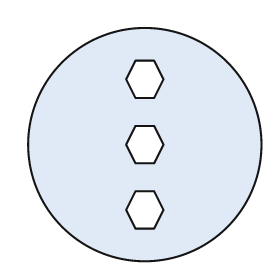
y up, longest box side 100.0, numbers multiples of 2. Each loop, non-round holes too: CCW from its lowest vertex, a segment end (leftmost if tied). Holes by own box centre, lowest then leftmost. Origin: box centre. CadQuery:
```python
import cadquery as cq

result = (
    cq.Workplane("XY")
    .moveTo(0.0, 0.0)
    .circle(50.0)
    .moveTo(-4.0, -36.0)
    .lineTo(4.0, -36.0)
    .lineTo(8.0, -28.0)
    .lineTo(4.0, -20.0)
    .lineTo(-4.0, -20.0)
    .lineTo(-8.0, -28.0)
    .close()
    .moveTo(-4.0, -8.0)
    .lineTo(4.0, -8.0)
    .lineTo(8.0, 0.0)
    .lineTo(4.0, 8.0)
    .lineTo(-4.0, 8.0)
    .lineTo(-8.0, 0.0)
    .close()
    .moveTo(-4.0, 20.0)
    .lineTo(4.0, 20.0)
    .lineTo(8.0, 28.0)
    .lineTo(4.0, 36.0)
    .lineTo(-4.0, 36.0)
    .lineTo(-8.0, 28.0)
    .close()
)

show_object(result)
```